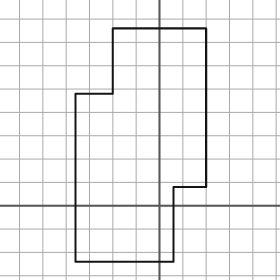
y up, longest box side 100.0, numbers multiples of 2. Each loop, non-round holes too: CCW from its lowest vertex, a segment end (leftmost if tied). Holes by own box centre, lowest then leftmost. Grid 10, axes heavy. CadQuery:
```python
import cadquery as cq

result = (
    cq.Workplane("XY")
    .moveTo(-36.0, -24.0)
    .lineTo(6.0, -24.0)
    .lineTo(6.0, 8.0)
    .lineTo(20.0, 8.0)
    .lineTo(20.0, 76.0)
    .lineTo(-20.0, 76.0)
    .lineTo(-20.0, 48.0)
    .lineTo(-36.0, 48.0)
    .close()
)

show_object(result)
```